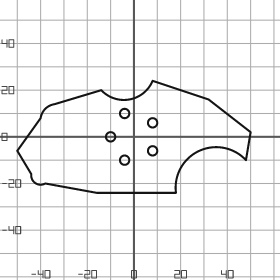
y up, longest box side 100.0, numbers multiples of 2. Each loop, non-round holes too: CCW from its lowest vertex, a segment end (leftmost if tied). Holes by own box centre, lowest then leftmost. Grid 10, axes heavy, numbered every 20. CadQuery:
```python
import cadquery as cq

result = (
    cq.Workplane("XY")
    .moveTo(-16.0, -24.0)
    .lineTo(18.0, -24.0)
    .threePointArc((28.0, -6.0), (48.0, -10.0))
    .lineTo(50.0, 2.0)
    .lineTo(32.0, 16.0)
    .lineTo(8.0, 24.0)
    .threePointArc((-2.0, 16.0), (-14.0, 20.0))
    .lineTo(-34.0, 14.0)
    .threePointArc((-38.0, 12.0), (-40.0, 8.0))
    .lineTo(-50.0, -6.0)
    .lineTo(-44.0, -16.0)
    .threePointArc((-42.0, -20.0), (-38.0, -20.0))
    .close()
    .moveTo(-4.0, -10.0)
    .circle(2.0)
    .moveTo(8.0, -6.0)
    .circle(2.0)
    .moveTo(-10.0, 0.0)
    .circle(2.0)
    .moveTo(8.0, 6.0)
    .circle(2.0)
    .moveTo(-4.0, 10.0)
    .circle(2.0)
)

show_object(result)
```